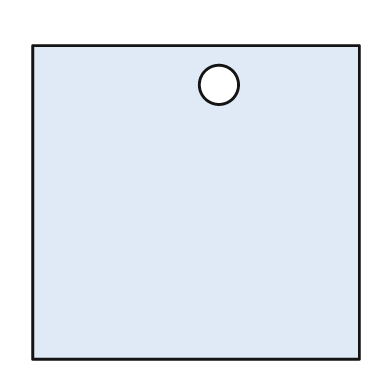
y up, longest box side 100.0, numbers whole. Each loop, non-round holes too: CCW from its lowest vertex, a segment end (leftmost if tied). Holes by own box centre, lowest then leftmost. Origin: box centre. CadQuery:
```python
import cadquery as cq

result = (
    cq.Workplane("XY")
    .moveTo(-50.0, -48.0)
    .lineTo(50.0, -48.0)
    .lineTo(50.0, 48.0)
    .lineTo(-50.0, 48.0)
    .close()
    .moveTo(7.0, 36.0)
    .circle(6.0)
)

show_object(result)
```